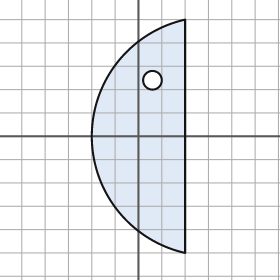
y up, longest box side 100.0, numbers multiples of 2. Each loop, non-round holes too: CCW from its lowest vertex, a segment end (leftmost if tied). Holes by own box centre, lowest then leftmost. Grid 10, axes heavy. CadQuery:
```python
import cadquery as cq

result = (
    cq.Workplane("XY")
    .moveTo(20.0, -50.0)
    .lineTo(20.0, 50.0)
    .threePointArc((-20.0, 0.0), (20.0, -50.0))
    .close()
    .moveTo(6.0, 24.0)
    .circle(4.0)
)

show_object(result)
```